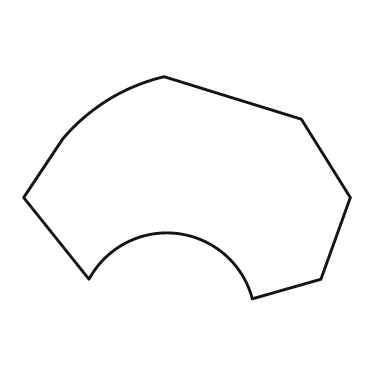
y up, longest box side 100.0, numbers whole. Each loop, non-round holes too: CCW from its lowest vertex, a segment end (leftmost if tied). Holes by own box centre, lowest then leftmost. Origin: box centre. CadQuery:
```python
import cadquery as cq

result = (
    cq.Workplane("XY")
    .moveTo(20.0, -34.0)
    .lineTo(41.0, -28.0)
    .lineTo(50.0, -3.0)
    .lineTo(35.0, 21.0)
    .lineTo(-7.0, 34.0)
    .threePointArc((-24.0, 27.0), (-38.0, 15.0))
    .lineTo(-50.0, -3.0)
    .lineTo(-30.0, -28.0)
    .threePointArc((-3.0, -14.0), (20.0, -34.0))
    .close()
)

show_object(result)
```